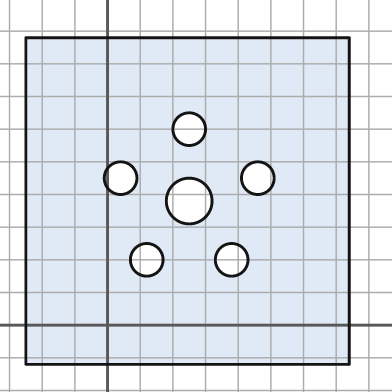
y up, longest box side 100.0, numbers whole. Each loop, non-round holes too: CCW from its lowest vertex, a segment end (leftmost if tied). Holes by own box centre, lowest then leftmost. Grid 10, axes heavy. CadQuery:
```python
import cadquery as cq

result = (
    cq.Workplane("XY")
    .moveTo(-25.0, -12.0)
    .lineTo(74.0, -12.0)
    .lineTo(74.0, 88.0)
    .lineTo(-25.0, 88.0)
    .close()
    .moveTo(12.0, 20.0)
    .circle(5.0)
    .moveTo(38.0, 20.0)
    .circle(5.0)
    .moveTo(25.0, 38.0)
    .circle(7.0)
    .moveTo(4.0, 45.0)
    .circle(5.0)
    .moveTo(46.0, 45.0)
    .circle(5.0)
    .moveTo(25.0, 60.0)
    .circle(5.0)
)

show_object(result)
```